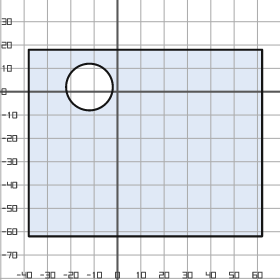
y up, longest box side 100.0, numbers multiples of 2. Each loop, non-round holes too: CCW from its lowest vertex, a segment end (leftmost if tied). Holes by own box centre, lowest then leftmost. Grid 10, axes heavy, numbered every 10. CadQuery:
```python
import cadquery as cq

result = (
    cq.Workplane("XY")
    .moveTo(-38.0, -62.0)
    .lineTo(62.0, -62.0)
    .lineTo(62.0, 18.0)
    .lineTo(-38.0, 18.0)
    .close()
    .moveTo(-12.0, 2.0)
    .circle(10.0)
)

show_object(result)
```